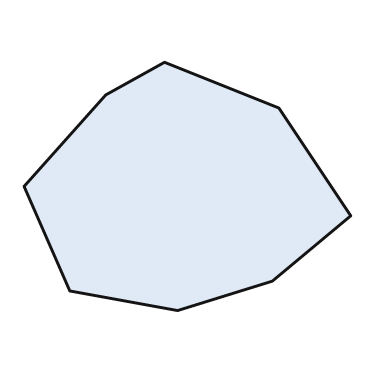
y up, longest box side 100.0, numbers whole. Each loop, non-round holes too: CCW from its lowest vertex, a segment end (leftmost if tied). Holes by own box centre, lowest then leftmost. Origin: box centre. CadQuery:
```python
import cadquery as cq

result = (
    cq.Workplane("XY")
    .moveTo(-3.0, -38.0)
    .lineTo(26.0, -29.0)
    .lineTo(50.0, -9.0)
    .lineTo(28.0, 24.0)
    .lineTo(-7.0, 38.0)
    .lineTo(-25.0, 28.0)
    .lineTo(-50.0, 0.0)
    .lineTo(-36.0, -32.0)
    .close()
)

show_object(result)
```